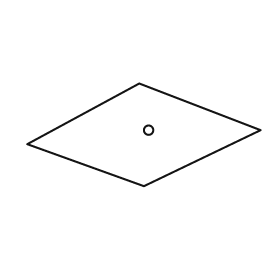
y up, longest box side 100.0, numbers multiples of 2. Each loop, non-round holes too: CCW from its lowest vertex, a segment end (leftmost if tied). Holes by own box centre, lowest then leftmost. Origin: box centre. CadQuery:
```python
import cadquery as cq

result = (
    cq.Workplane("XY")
    .moveTo(0.0, -22.0)
    .lineTo(50.0, 2.0)
    .lineTo(-2.0, 22.0)
    .lineTo(-50.0, -4.0)
    .close()
    .moveTo(2.0, 2.0)
    .circle(2.0)
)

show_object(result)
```